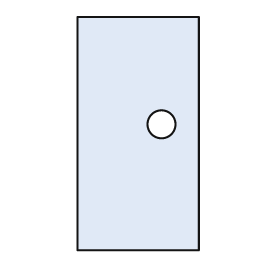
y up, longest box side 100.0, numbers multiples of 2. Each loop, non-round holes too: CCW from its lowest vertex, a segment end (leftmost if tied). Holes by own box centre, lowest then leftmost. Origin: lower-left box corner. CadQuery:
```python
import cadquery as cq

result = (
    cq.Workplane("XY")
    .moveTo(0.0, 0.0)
    .lineTo(52.0, 0.0)
    .lineTo(52.0, 100.0)
    .lineTo(0.0, 100.0)
    .close()
    .moveTo(36.0, 54.0)
    .circle(6.0)
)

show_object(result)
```